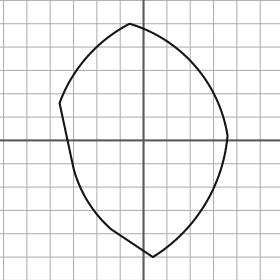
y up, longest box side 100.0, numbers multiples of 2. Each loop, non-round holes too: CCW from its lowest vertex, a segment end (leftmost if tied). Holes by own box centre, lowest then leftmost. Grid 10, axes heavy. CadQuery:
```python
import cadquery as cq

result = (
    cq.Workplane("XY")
    .moveTo(4.0, -50.0)
    .threePointArc((26.0, -28.0), (36.0, 2.0))
    .threePointArc((22.0, 32.0), (-6.0, 50.0))
    .threePointArc((-24.0, 36.0), (-36.0, 16.0))
    .lineTo(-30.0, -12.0)
    .threePointArc((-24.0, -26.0), (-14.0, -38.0))
    .close()
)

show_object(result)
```